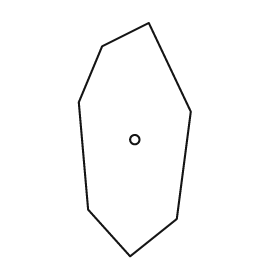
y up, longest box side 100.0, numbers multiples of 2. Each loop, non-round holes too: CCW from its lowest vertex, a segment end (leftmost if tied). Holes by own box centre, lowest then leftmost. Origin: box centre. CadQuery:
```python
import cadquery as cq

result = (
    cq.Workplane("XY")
    .moveTo(-2.0, -50.0)
    .lineTo(18.0, -34.0)
    .lineTo(24.0, 12.0)
    .lineTo(6.0, 50.0)
    .lineTo(-14.0, 40.0)
    .lineTo(-24.0, 16.0)
    .lineTo(-20.0, -30.0)
    .close()
    .moveTo(0.0, 0.0)
    .circle(2.0)
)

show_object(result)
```